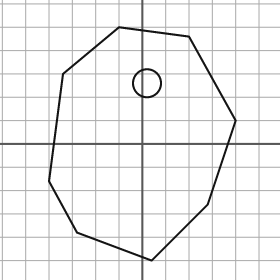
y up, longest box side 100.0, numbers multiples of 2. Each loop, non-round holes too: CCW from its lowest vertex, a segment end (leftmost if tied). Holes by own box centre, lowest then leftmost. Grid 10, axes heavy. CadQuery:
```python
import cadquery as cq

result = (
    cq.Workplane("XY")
    .moveTo(4.0, -50.0)
    .lineTo(28.0, -26.0)
    .lineTo(40.0, 10.0)
    .lineTo(20.0, 46.0)
    .lineTo(-10.0, 50.0)
    .lineTo(-34.0, 30.0)
    .lineTo(-40.0, -16.0)
    .lineTo(-28.0, -38.0)
    .close()
    .moveTo(2.0, 26.0)
    .circle(6.0)
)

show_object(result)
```